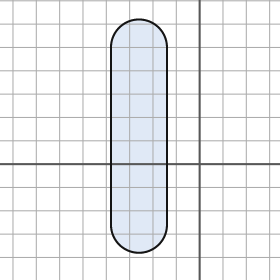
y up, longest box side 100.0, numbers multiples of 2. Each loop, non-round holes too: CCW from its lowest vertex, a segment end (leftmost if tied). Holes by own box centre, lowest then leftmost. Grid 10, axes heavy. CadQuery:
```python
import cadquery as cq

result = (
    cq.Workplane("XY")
    .moveTo(-38.0, -26.0)
    .threePointArc((-26.0, -38.0), (-14.0, -26.0))
    .lineTo(-14.0, 50.0)
    .threePointArc((-26.0, 62.0), (-38.0, 50.0))
    .close()
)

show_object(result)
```